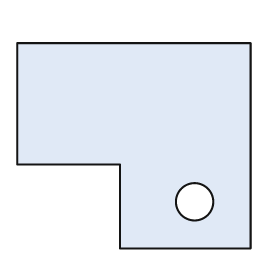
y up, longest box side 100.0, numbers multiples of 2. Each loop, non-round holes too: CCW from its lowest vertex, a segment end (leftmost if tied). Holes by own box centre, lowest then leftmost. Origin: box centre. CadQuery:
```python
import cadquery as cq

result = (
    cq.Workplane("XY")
    .moveTo(-6.0, -44.0)
    .lineTo(50.0, -44.0)
    .lineTo(50.0, 44.0)
    .lineTo(-50.0, 44.0)
    .lineTo(-50.0, -8.0)
    .lineTo(-6.0, -8.0)
    .close()
    .moveTo(26.0, -24.0)
    .circle(8.0)
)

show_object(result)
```